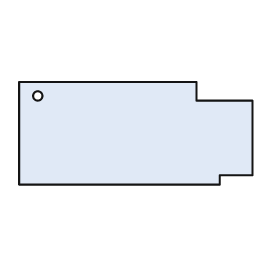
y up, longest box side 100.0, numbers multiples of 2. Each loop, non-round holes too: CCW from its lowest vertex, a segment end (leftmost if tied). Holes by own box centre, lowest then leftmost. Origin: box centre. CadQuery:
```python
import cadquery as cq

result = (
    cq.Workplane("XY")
    .moveTo(-50.0, -22.0)
    .lineTo(36.0, -22.0)
    .lineTo(36.0, -18.0)
    .lineTo(50.0, -18.0)
    .lineTo(50.0, 14.0)
    .lineTo(26.0, 14.0)
    .lineTo(26.0, 22.0)
    .lineTo(-50.0, 22.0)
    .close()
    .moveTo(-42.0, 16.0)
    .circle(2.0)
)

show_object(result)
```